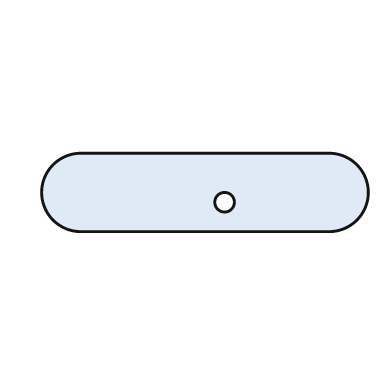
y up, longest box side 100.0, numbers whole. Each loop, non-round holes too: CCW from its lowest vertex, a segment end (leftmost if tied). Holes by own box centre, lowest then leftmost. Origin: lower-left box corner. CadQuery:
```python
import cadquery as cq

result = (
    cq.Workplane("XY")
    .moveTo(12.0, 0.0)
    .lineTo(88.0, 0.0)
    .threePointArc((100.0, 12.0), (88.0, 24.0))
    .lineTo(12.0, 24.0)
    .threePointArc((0.0, 12.0), (12.0, 0.0))
    .close()
    .moveTo(56.0, 9.0)
    .circle(3.0)
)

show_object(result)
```